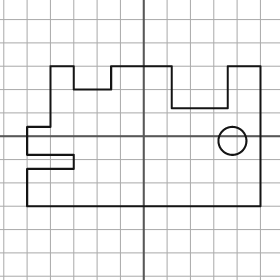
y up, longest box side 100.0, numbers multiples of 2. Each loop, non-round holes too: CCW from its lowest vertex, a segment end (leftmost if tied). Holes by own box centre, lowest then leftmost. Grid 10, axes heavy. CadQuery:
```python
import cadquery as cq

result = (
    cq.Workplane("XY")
    .moveTo(-50.0, -30.0)
    .lineTo(50.0, -30.0)
    .lineTo(50.0, 30.0)
    .lineTo(36.0, 30.0)
    .lineTo(36.0, 12.0)
    .lineTo(12.0, 12.0)
    .lineTo(12.0, 30.0)
    .lineTo(-14.0, 30.0)
    .lineTo(-14.0, 20.0)
    .lineTo(-30.0, 20.0)
    .lineTo(-30.0, 30.0)
    .lineTo(-40.0, 30.0)
    .lineTo(-40.0, 4.0)
    .lineTo(-50.0, 4.0)
    .lineTo(-50.0, -8.0)
    .lineTo(-30.0, -8.0)
    .lineTo(-30.0, -14.0)
    .lineTo(-50.0, -14.0)
    .close()
    .moveTo(38.0, -2.0)
    .circle(6.0)
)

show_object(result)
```